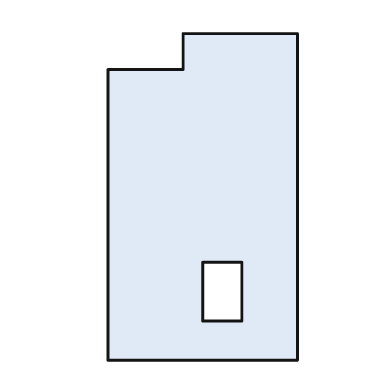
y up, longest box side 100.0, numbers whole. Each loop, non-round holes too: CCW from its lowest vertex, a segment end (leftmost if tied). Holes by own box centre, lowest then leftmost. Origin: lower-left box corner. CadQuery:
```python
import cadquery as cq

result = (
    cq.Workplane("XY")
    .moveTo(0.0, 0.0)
    .lineTo(58.0, 0.0)
    .lineTo(58.0, 100.0)
    .lineTo(23.0, 100.0)
    .lineTo(23.0, 89.0)
    .lineTo(0.0, 89.0)
    .close()
    .moveTo(29.0, 12.0)
    .lineTo(41.0, 12.0)
    .lineTo(41.0, 30.0)
    .lineTo(29.0, 30.0)
    .close()
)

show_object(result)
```